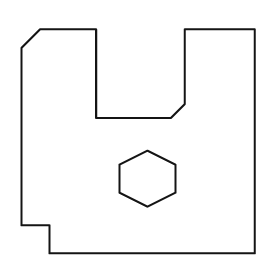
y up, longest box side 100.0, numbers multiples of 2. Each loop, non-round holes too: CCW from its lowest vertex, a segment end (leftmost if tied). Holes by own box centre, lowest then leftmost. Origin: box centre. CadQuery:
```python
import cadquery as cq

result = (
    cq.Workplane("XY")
    .moveTo(-38.0, -48.0)
    .lineTo(50.0, -48.0)
    .lineTo(50.0, 48.0)
    .lineTo(20.0, 48.0)
    .lineTo(20.0, 16.0)
    .lineTo(14.0, 10.0)
    .lineTo(-18.0, 10.0)
    .lineTo(-18.0, 48.0)
    .lineTo(-42.0, 48.0)
    .lineTo(-50.0, 40.0)
    .lineTo(-50.0, -36.0)
    .lineTo(-38.0, -36.0)
    .close()
    .moveTo(4.0, -28.0)
    .lineTo(16.0, -22.0)
    .lineTo(16.0, -10.0)
    .lineTo(4.0, -4.0)
    .lineTo(-8.0, -10.0)
    .lineTo(-8.0, -22.0)
    .close()
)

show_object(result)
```